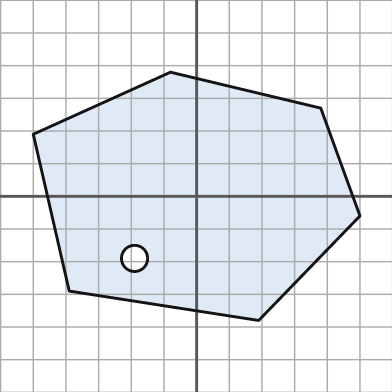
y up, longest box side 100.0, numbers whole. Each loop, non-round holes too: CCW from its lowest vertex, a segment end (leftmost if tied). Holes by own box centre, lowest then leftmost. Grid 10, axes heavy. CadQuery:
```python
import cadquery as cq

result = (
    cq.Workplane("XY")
    .moveTo(19.0, -38.0)
    .lineTo(50.0, -6.0)
    .lineTo(38.0, 27.0)
    .lineTo(-8.0, 38.0)
    .lineTo(-50.0, 19.0)
    .lineTo(-39.0, -29.0)
    .close()
    .moveTo(-19.0, -19.0)
    .circle(4.0)
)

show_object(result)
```